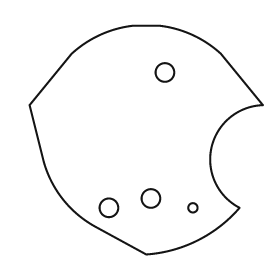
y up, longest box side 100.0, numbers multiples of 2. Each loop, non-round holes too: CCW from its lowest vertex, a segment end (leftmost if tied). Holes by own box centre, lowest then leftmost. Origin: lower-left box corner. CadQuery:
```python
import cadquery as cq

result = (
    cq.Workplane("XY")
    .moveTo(50.0, 0.0)
    .threePointArc((72.0, 6.0), (90.0, 20.0))
    .threePointArc((78.0, 46.0), (100.0, 64.0))
    .lineTo(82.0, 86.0)
    .threePointArc((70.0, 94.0), (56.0, 98.0))
    .lineTo(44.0, 98.0)
    .threePointArc((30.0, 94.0), (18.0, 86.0))
    .lineTo(0.0, 64.0)
    .lineTo(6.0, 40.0)
    .threePointArc((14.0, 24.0), (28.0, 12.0))
    .close()
    .moveTo(34.0, 20.0)
    .circle(4.0)
    .moveTo(70.0, 20.0)
    .circle(2.0)
    .moveTo(52.0, 24.0)
    .circle(4.0)
    .moveTo(58.0, 78.0)
    .circle(4.0)
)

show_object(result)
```